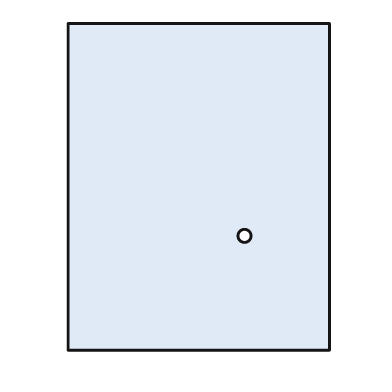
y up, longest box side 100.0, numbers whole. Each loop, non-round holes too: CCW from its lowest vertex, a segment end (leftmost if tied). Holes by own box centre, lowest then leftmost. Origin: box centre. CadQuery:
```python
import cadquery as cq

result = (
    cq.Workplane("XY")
    .moveTo(-40.0, -50.0)
    .lineTo(40.0, -50.0)
    .lineTo(40.0, 50.0)
    .lineTo(-40.0, 50.0)
    .close()
    .moveTo(14.0, -15.0)
    .circle(2.0)
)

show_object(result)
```